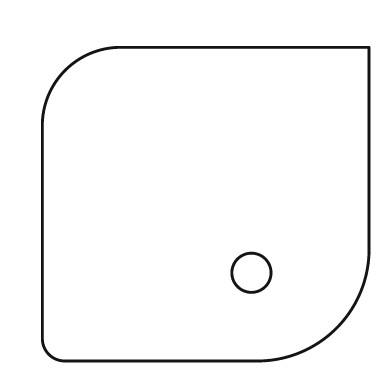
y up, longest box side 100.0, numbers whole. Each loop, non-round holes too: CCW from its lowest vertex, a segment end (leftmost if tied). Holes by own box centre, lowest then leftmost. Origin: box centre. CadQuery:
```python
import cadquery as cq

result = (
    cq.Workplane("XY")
    .moveTo(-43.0, -48.0)
    .lineTo(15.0, -48.0)
    .threePointArc((40.0, -38.0), (50.0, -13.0))
    .lineTo(50.0, 48.0)
    .lineTo(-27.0, 48.0)
    .threePointArc((-43.0, 41.0), (-50.0, 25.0))
    .lineTo(-50.0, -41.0)
    .threePointArc((-48.0, -46.0), (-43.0, -48.0))
    .close()
    .moveTo(14.0, -21.0)
    .circle(6.0)
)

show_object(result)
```